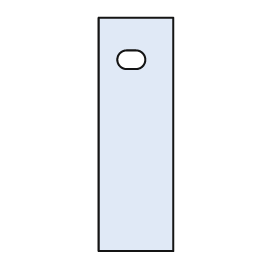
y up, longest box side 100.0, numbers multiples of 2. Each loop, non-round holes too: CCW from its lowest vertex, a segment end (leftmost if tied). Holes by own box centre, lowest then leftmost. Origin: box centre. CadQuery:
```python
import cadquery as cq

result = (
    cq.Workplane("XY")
    .moveTo(-16.0, -50.0)
    .lineTo(16.0, -50.0)
    .lineTo(16.0, 50.0)
    .lineTo(-16.0, 50.0)
    .close()
    .moveTo(-4.0, 28.0)
    .lineTo(0.0, 28.0)
    .threePointArc((4.0, 32.0), (0.0, 36.0))
    .lineTo(-4.0, 36.0)
    .threePointArc((-8.0, 32.0), (-4.0, 28.0))
    .close()
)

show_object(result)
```